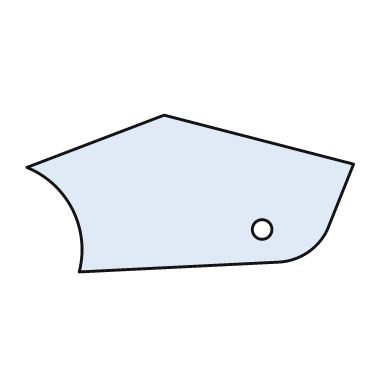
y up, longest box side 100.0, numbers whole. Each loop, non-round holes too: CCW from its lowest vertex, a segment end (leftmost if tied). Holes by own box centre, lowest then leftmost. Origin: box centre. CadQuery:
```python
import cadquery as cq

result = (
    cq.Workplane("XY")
    .moveTo(-34.0, -24.0)
    .lineTo(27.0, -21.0)
    .threePointArc((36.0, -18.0), (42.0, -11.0))
    .lineTo(50.0, 9.0)
    .lineTo(-8.0, 24.0)
    .lineTo(-50.0, 8.0)
    .threePointArc((-36.0, -5.0), (-34.0, -24.0))
    .close()
    .moveTo(22.0, -11.0)
    .circle(3.0)
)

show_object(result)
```